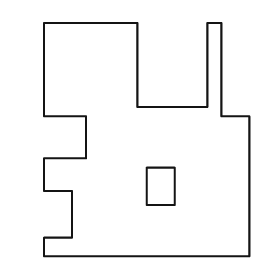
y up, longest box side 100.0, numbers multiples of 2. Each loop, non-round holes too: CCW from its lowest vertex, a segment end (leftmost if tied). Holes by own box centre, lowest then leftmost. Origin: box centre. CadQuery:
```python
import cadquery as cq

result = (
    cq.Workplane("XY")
    .moveTo(-44.0, -50.0)
    .lineTo(44.0, -50.0)
    .lineTo(44.0, 10.0)
    .lineTo(32.0, 10.0)
    .lineTo(32.0, 50.0)
    .lineTo(26.0, 50.0)
    .lineTo(26.0, 14.0)
    .lineTo(-4.0, 14.0)
    .lineTo(-4.0, 50.0)
    .lineTo(-44.0, 50.0)
    .lineTo(-44.0, 10.0)
    .lineTo(-26.0, 10.0)
    .lineTo(-26.0, -8.0)
    .lineTo(-44.0, -8.0)
    .lineTo(-44.0, -22.0)
    .lineTo(-32.0, -22.0)
    .lineTo(-32.0, -42.0)
    .lineTo(-44.0, -42.0)
    .close()
    .moveTo(0.0, -28.0)
    .lineTo(12.0, -28.0)
    .lineTo(12.0, -12.0)
    .lineTo(0.0, -12.0)
    .close()
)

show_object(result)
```